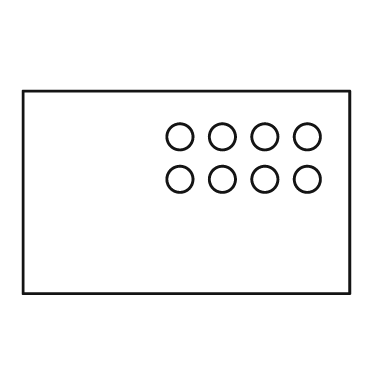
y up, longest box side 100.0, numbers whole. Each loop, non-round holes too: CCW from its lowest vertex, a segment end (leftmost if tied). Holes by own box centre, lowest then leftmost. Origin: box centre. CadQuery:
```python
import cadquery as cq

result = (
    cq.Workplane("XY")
    .moveTo(-50.0, -31.0)
    .lineTo(50.0, -31.0)
    .lineTo(50.0, 31.0)
    .lineTo(-50.0, 31.0)
    .close()
    .moveTo(-2.0, 4.0)
    .circle(4.0)
    .moveTo(11.0, 4.0)
    .circle(4.0)
    .moveTo(24.0, 4.0)
    .circle(4.0)
    .moveTo(37.0, 4.0)
    .circle(4.0)
    .moveTo(-2.0, 17.0)
    .circle(4.0)
    .moveTo(11.0, 17.0)
    .circle(4.0)
    .moveTo(24.0, 17.0)
    .circle(4.0)
    .moveTo(37.0, 17.0)
    .circle(4.0)
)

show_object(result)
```